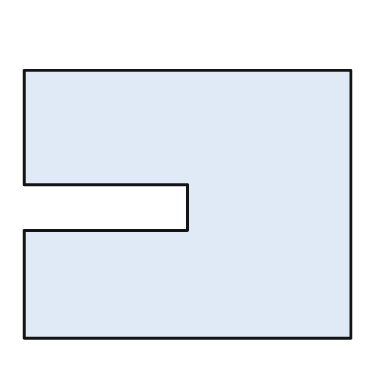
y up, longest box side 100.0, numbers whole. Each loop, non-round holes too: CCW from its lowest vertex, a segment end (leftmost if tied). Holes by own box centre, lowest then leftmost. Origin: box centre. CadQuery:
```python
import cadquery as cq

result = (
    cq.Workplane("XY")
    .moveTo(-50.0, -41.0)
    .lineTo(50.0, -41.0)
    .lineTo(50.0, 41.0)
    .lineTo(-50.0, 41.0)
    .lineTo(-50.0, 6.0)
    .lineTo(0.0, 6.0)
    .lineTo(0.0, -8.0)
    .lineTo(-50.0, -8.0)
    .close()
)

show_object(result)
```